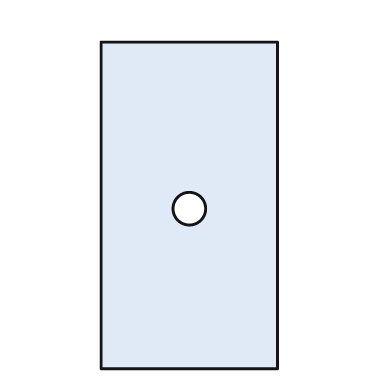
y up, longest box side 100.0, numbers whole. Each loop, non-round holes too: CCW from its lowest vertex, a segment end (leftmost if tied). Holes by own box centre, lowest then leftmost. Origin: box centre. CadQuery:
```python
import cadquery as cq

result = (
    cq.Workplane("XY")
    .moveTo(-27.0, -50.0)
    .lineTo(27.0, -50.0)
    .lineTo(27.0, 50.0)
    .lineTo(-27.0, 50.0)
    .close()
    .moveTo(0.0, -1.0)
    .circle(5.0)
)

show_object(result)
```